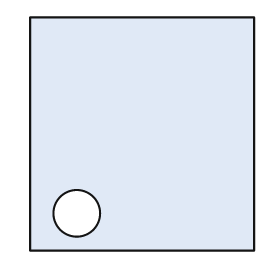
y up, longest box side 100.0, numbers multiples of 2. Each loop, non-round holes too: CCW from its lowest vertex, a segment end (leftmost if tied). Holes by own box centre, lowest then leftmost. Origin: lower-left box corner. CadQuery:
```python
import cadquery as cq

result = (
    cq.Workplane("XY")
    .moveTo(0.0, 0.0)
    .lineTo(96.0, 0.0)
    .lineTo(96.0, 100.0)
    .lineTo(0.0, 100.0)
    .close()
    .moveTo(20.0, 16.0)
    .circle(10.0)
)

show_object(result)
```